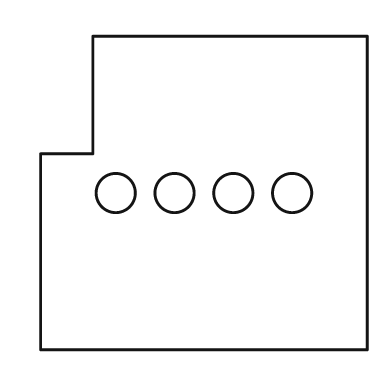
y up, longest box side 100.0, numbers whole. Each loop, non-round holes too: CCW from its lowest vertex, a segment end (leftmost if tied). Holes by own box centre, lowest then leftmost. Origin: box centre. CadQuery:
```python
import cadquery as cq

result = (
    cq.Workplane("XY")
    .moveTo(-50.0, -48.0)
    .lineTo(50.0, -48.0)
    .lineTo(50.0, 48.0)
    .lineTo(-34.0, 48.0)
    .lineTo(-34.0, 12.0)
    .lineTo(-50.0, 12.0)
    .close()
    .moveTo(-27.0, 0.0)
    .circle(6.0)
    .moveTo(-9.0, 0.0)
    .circle(6.0)
    .moveTo(9.0, 0.0)
    .circle(6.0)
    .moveTo(27.0, 0.0)
    .circle(6.0)
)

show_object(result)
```